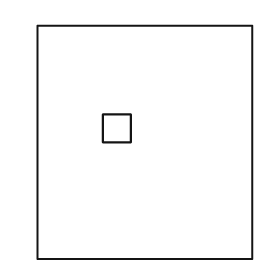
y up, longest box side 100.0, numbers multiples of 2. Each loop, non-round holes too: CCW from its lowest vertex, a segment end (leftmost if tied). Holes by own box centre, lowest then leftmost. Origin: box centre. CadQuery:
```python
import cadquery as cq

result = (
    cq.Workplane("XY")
    .moveTo(-46.0, -50.0)
    .lineTo(46.0, -50.0)
    .lineTo(46.0, 50.0)
    .lineTo(-46.0, 50.0)
    .close()
    .moveTo(-18.0, 0.0)
    .lineTo(-6.0, 0.0)
    .lineTo(-6.0, 12.0)
    .lineTo(-18.0, 12.0)
    .close()
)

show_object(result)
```